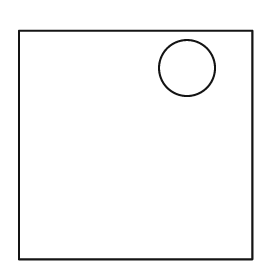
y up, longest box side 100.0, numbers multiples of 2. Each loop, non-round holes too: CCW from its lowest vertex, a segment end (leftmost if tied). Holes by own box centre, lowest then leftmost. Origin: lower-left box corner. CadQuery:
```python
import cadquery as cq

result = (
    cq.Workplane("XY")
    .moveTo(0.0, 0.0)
    .lineTo(100.0, 0.0)
    .lineTo(100.0, 98.0)
    .lineTo(0.0, 98.0)
    .close()
    .moveTo(72.0, 82.0)
    .circle(12.0)
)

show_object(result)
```